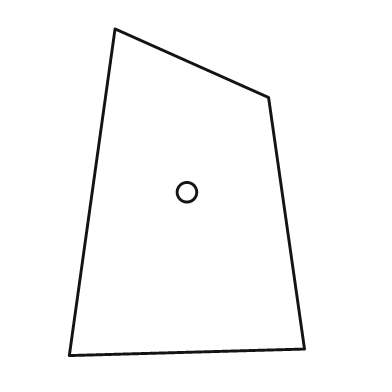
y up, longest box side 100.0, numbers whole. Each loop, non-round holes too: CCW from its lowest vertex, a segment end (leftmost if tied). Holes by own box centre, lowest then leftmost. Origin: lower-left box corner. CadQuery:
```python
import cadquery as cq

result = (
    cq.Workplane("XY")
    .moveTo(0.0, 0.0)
    .lineTo(72.0, 2.0)
    .lineTo(61.0, 79.0)
    .lineTo(14.0, 100.0)
    .close()
    .moveTo(36.0, 50.0)
    .circle(3.0)
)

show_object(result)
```